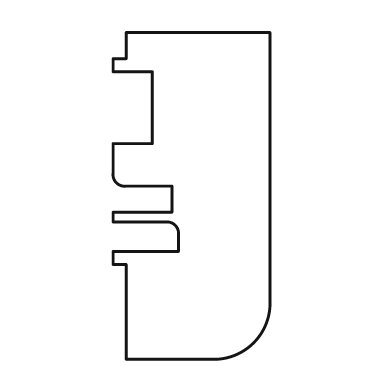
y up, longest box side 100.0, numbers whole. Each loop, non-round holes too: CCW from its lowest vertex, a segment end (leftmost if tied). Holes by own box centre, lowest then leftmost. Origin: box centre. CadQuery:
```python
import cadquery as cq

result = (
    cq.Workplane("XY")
    .moveTo(-20.0, -50.0)
    .lineTo(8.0, -50.0)
    .threePointArc((19.0, -45.0), (24.0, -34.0))
    .lineTo(24.0, 50.0)
    .lineTo(-20.0, 50.0)
    .lineTo(-20.0, 42.0)
    .lineTo(-24.0, 42.0)
    .lineTo(-24.0, 38.0)
    .lineTo(-12.0, 38.0)
    .lineTo(-12.0, 16.0)
    .lineTo(-24.0, 16.0)
    .lineTo(-24.0, 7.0)
    .threePointArc((-23.0, 4.0), (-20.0, 3.0))
    .lineTo(-6.0, 3.0)
    .lineTo(-6.0, -5.0)
    .lineTo(-24.0, -5.0)
    .lineTo(-24.0, -8.0)
    .lineTo(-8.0, -8.0)
    .threePointArc((-5.0, -9.0), (-4.0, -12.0))
    .lineTo(-4.0, -17.0)
    .lineTo(-24.0, -17.0)
    .lineTo(-24.0, -21.0)
    .lineTo(-20.0, -21.0)
    .close()
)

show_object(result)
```